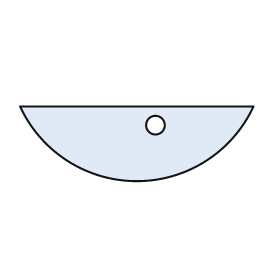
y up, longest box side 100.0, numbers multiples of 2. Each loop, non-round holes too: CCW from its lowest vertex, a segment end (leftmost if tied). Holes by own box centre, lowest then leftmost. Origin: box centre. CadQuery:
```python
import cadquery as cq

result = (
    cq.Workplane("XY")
    .moveTo(-50.0, 16.0)
    .threePointArc((0.0, -16.0), (50.0, 16.0))
    .close()
    .moveTo(8.0, 8.0)
    .circle(4.0)
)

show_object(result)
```